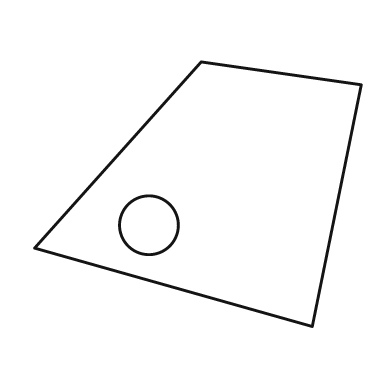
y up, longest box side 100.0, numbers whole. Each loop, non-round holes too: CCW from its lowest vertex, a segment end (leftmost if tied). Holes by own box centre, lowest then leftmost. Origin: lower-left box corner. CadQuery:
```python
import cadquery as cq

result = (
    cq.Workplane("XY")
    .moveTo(85.0, 0.0)
    .lineTo(100.0, 74.0)
    .lineTo(51.0, 81.0)
    .lineTo(0.0, 24.0)
    .close()
    .moveTo(35.0, 31.0)
    .circle(9.0)
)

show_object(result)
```